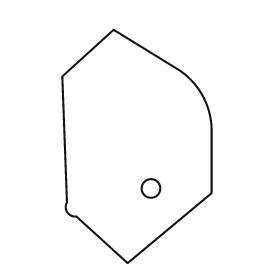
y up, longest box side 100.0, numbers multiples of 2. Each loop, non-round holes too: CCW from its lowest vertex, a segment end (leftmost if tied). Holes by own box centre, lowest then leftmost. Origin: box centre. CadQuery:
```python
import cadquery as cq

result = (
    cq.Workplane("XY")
    .moveTo(-4.0, -50.0)
    .lineTo(32.0, -20.0)
    .lineTo(32.0, 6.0)
    .threePointArc((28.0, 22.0), (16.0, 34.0))
    .lineTo(-10.0, 50.0)
    .lineTo(-32.0, 30.0)
    .lineTo(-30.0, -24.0)
    .threePointArc((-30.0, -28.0), (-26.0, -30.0))
    .close()
    .moveTo(6.0, -18.0)
    .circle(4.0)
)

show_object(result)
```